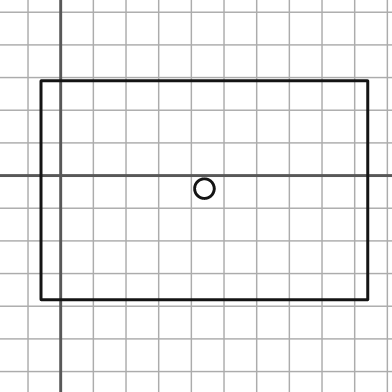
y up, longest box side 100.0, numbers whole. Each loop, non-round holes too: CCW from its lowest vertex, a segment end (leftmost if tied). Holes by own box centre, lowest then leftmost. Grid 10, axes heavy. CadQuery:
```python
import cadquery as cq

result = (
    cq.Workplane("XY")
    .moveTo(-6.0, -38.0)
    .lineTo(94.0, -38.0)
    .lineTo(94.0, 29.0)
    .lineTo(-6.0, 29.0)
    .close()
    .moveTo(44.0, -4.0)
    .circle(3.0)
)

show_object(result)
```